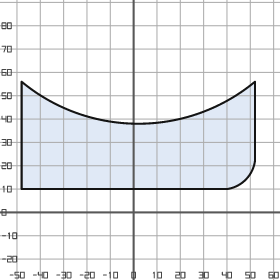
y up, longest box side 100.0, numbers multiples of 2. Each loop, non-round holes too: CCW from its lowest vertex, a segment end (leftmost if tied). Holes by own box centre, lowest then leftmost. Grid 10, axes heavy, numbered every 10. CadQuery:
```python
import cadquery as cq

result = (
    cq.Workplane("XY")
    .moveTo(-48.0, 10.0)
    .lineTo(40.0, 10.0)
    .threePointArc((48.0, 14.0), (52.0, 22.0))
    .lineTo(52.0, 56.0)
    .threePointArc((2.0, 38.0), (-48.0, 56.0))
    .close()
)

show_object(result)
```